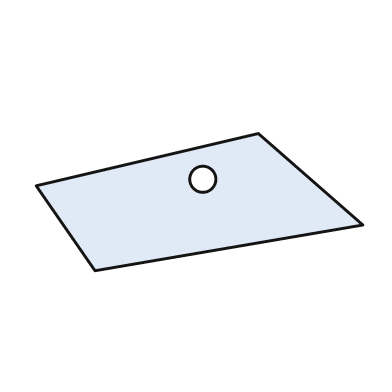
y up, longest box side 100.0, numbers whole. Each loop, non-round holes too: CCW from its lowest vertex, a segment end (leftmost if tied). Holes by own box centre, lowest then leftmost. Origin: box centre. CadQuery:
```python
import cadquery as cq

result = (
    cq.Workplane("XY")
    .moveTo(-32.0, -21.0)
    .lineTo(50.0, -7.0)
    .lineTo(18.0, 21.0)
    .lineTo(-50.0, 5.0)
    .close()
    .moveTo(1.0, 7.0)
    .circle(4.0)
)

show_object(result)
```